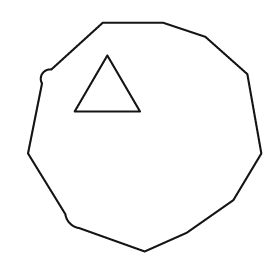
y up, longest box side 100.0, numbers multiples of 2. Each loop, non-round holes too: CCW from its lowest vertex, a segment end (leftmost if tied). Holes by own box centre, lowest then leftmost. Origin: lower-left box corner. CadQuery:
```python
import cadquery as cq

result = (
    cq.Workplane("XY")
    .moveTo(50.0, 0.0)
    .lineTo(68.0, 8.0)
    .lineTo(88.0, 22.0)
    .lineTo(100.0, 42.0)
    .lineTo(94.0, 76.0)
    .lineTo(76.0, 92.0)
    .lineTo(58.0, 98.0)
    .lineTo(32.0, 98.0)
    .lineTo(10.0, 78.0)
    .threePointArc((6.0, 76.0), (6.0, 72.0))
    .lineTo(0.0, 42.0)
    .lineTo(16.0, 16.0)
    .threePointArc((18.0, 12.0), (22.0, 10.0))
    .close()
    .moveTo(20.0, 60.0)
    .lineTo(48.0, 60.0)
    .lineTo(34.0, 84.0)
    .close()
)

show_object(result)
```